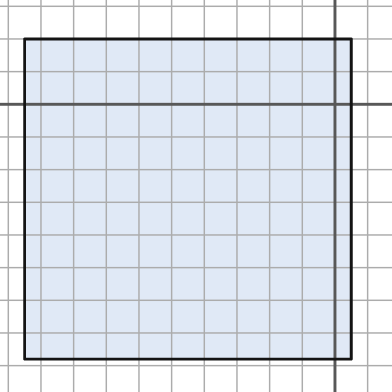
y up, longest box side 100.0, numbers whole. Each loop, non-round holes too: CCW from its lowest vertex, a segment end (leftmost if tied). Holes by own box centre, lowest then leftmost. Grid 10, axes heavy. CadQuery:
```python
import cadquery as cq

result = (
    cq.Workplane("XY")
    .moveTo(-95.0, -78.0)
    .lineTo(5.0, -78.0)
    .lineTo(5.0, 20.0)
    .lineTo(-95.0, 20.0)
    .close()
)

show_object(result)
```